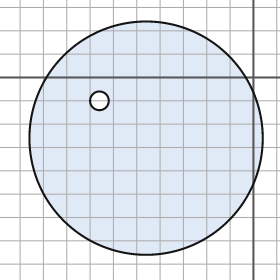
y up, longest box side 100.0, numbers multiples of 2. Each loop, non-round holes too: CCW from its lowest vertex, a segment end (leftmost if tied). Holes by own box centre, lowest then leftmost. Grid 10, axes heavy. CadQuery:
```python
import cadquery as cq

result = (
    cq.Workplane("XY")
    .moveTo(-46.0, -26.0)
    .circle(50.0)
    .moveTo(-66.0, -10.0)
    .circle(4.0)
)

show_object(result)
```